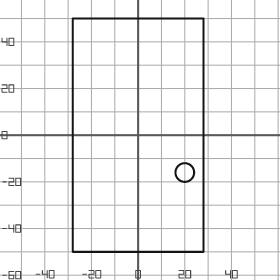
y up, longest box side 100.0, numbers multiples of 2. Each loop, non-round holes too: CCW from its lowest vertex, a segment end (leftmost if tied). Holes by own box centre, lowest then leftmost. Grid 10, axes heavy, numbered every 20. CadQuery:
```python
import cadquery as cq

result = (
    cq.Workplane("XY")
    .moveTo(-28.0, -50.0)
    .lineTo(28.0, -50.0)
    .lineTo(28.0, 50.0)
    .lineTo(-28.0, 50.0)
    .close()
    .moveTo(20.0, -16.0)
    .circle(4.0)
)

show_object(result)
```